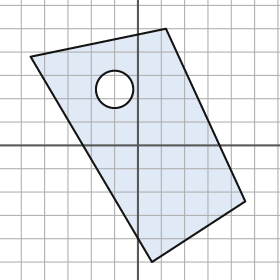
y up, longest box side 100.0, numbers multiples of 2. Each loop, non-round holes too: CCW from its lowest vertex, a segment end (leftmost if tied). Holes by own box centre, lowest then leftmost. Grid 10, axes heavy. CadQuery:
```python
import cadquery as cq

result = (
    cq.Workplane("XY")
    .moveTo(6.0, -50.0)
    .lineTo(46.0, -24.0)
    .lineTo(12.0, 50.0)
    .lineTo(-46.0, 38.0)
    .close()
    .moveTo(-10.0, 24.0)
    .circle(8.0)
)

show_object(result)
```